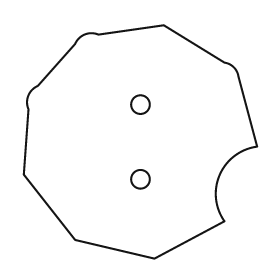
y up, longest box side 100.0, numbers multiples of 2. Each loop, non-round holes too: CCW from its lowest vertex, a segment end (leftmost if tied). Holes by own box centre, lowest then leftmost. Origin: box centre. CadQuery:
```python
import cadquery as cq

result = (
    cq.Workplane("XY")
    .moveTo(6.0, -50.0)
    .lineTo(36.0, -34.0)
    .threePointArc((34.0, -14.0), (50.0, -2.0))
    .lineTo(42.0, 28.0)
    .threePointArc((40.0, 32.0), (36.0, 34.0))
    .lineTo(10.0, 50.0)
    .lineTo(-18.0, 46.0)
    .threePointArc((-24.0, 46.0), (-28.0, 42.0))
    .lineTo(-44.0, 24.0)
    .threePointArc((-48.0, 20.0), (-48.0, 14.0))
    .lineTo(-50.0, -14.0)
    .lineTo(-28.0, -42.0)
    .close()
    .moveTo(0.0, -16.0)
    .circle(4.0)
    .moveTo(0.0, 16.0)
    .circle(4.0)
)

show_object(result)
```